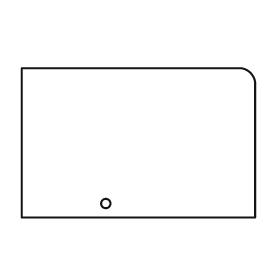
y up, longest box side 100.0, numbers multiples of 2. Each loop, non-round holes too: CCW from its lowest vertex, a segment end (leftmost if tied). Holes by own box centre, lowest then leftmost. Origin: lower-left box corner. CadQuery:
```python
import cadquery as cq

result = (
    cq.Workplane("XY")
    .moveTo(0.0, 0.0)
    .lineTo(100.0, 0.0)
    .lineTo(100.0, 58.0)
    .threePointArc((98.0, 62.0), (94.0, 64.0))
    .lineTo(0.0, 64.0)
    .close()
    .moveTo(36.0, 6.0)
    .circle(2.0)
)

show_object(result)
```